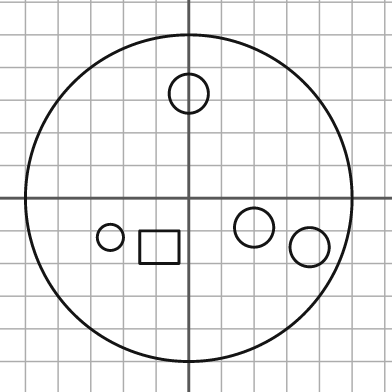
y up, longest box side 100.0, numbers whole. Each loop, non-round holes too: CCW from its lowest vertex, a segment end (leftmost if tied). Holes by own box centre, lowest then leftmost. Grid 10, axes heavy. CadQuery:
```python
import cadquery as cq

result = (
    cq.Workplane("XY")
    .moveTo(0.0, 0.0)
    .circle(50.0)
    .moveTo(-15.0, -20.0)
    .lineTo(-3.0, -20.0)
    .lineTo(-3.0, -10.0)
    .lineTo(-15.0, -10.0)
    .close()
    .moveTo(37.0, -15.0)
    .circle(6.0)
    .moveTo(-24.0, -12.0)
    .circle(4.0)
    .moveTo(20.0, -9.0)
    .circle(6.0)
    .moveTo(0.0, 32.0)
    .circle(6.0)
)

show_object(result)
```